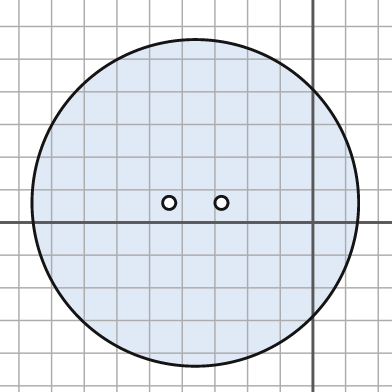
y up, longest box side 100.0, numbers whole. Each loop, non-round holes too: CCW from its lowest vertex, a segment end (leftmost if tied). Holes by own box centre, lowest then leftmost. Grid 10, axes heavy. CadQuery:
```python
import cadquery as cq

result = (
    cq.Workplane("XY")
    .moveTo(-36.0, 6.0)
    .circle(50.0)
    .moveTo(-44.0, 6.0)
    .circle(2.0)
    .moveTo(-28.0, 6.0)
    .circle(2.0)
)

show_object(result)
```